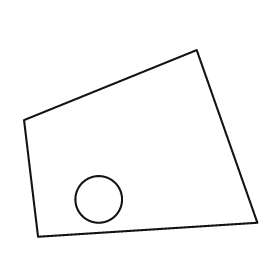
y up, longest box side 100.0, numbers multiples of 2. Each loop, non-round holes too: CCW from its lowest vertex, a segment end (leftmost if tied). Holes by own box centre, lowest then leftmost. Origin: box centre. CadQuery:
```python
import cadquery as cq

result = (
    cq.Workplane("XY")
    .moveTo(-44.0, -40.0)
    .lineTo(50.0, -34.0)
    .lineTo(24.0, 40.0)
    .lineTo(-50.0, 10.0)
    .close()
    .moveTo(-18.0, -24.0)
    .circle(10.0)
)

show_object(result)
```